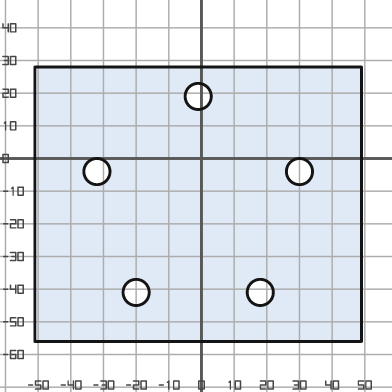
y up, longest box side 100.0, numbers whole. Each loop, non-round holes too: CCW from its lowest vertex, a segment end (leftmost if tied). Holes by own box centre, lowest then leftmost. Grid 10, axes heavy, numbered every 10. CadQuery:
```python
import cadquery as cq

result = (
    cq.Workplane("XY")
    .moveTo(-51.0, -56.0)
    .lineTo(49.0, -56.0)
    .lineTo(49.0, 28.0)
    .lineTo(-51.0, 28.0)
    .close()
    .moveTo(-20.0, -41.0)
    .circle(4.0)
    .moveTo(18.0, -41.0)
    .circle(4.0)
    .moveTo(-32.0, -4.0)
    .circle(4.0)
    .moveTo(30.0, -4.0)
    .circle(4.0)
    .moveTo(-1.0, 19.0)
    .circle(4.0)
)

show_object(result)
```